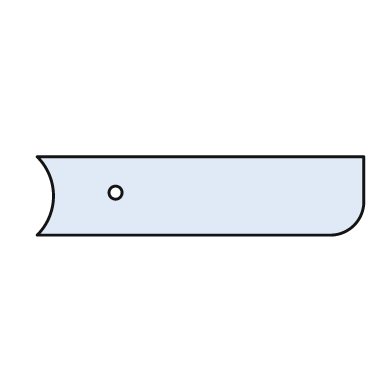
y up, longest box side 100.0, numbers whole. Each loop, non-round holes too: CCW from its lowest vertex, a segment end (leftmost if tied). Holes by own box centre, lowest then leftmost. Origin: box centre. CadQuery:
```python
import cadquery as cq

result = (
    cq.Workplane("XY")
    .moveTo(-50.0, -12.0)
    .lineTo(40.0, -12.0)
    .threePointArc((47.0, -9.0), (50.0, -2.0))
    .lineTo(50.0, 12.0)
    .lineTo(-50.0, 12.0)
    .threePointArc((-45.0, 0.0), (-50.0, -12.0))
    .close()
    .moveTo(-26.0, 1.0)
    .circle(2.0)
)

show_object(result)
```